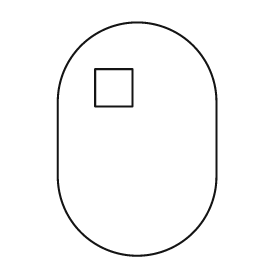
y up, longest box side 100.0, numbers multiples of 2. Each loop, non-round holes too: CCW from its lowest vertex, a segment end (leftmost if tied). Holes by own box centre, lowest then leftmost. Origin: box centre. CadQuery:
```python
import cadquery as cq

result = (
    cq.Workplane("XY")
    .moveTo(-34.0, -16.0)
    .threePointArc((0.0, -50.0), (34.0, -16.0))
    .lineTo(34.0, 16.0)
    .threePointArc((0.0, 50.0), (-34.0, 16.0))
    .close()
    .moveTo(-18.0, 14.0)
    .lineTo(-2.0, 14.0)
    .lineTo(-2.0, 30.0)
    .lineTo(-18.0, 30.0)
    .close()
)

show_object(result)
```